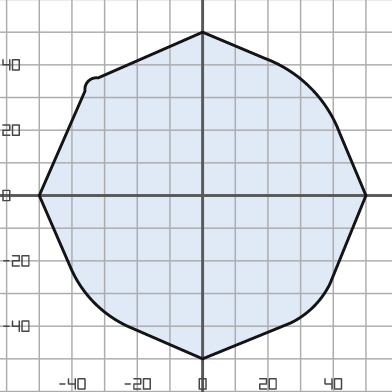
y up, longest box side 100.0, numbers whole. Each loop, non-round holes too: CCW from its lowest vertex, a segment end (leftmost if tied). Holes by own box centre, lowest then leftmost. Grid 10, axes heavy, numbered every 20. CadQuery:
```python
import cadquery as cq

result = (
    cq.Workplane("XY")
    .moveTo(0.0, -50.0)
    .lineTo(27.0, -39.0)
    .threePointArc((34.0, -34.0), (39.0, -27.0))
    .lineTo(50.0, 0.0)
    .lineTo(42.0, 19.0)
    .threePointArc((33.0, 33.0), (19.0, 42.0))
    .lineTo(0.0, 50.0)
    .lineTo(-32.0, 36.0)
    .threePointArc((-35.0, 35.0), (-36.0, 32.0))
    .lineTo(-50.0, 0.0)
    .lineTo(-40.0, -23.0)
    .threePointArc((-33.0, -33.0), (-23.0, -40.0))
    .close()
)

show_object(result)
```